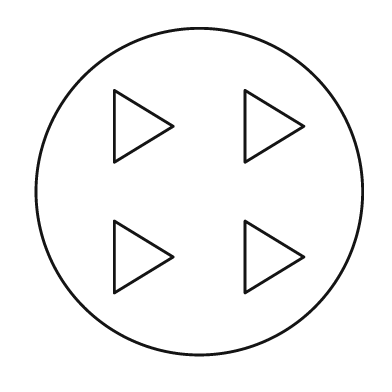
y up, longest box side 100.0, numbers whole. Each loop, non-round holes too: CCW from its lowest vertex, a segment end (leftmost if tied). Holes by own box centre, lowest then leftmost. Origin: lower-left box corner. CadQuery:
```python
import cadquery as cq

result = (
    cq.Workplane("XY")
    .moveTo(50.0, 50.0)
    .circle(50.0)
    .moveTo(24.0, 19.0)
    .lineTo(42.0, 30.0)
    .lineTo(24.0, 41.0)
    .close()
    .moveTo(64.0, 19.0)
    .lineTo(82.0, 30.0)
    .lineTo(64.0, 41.0)
    .close()
    .moveTo(24.0, 59.0)
    .lineTo(42.0, 70.0)
    .lineTo(24.0, 81.0)
    .close()
    .moveTo(64.0, 59.0)
    .lineTo(82.0, 70.0)
    .lineTo(64.0, 81.0)
    .close()
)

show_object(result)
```